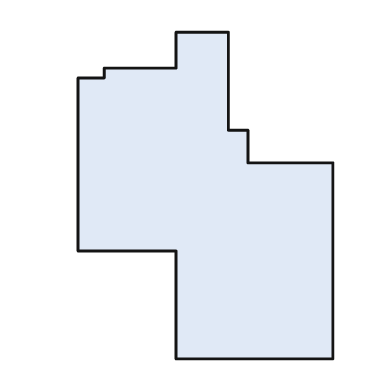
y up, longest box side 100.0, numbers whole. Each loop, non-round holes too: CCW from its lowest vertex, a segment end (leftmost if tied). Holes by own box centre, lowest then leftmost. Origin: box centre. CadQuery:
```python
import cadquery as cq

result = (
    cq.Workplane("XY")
    .moveTo(-9.0, -50.0)
    .lineTo(39.0, -50.0)
    .lineTo(39.0, 10.0)
    .lineTo(13.0, 10.0)
    .lineTo(13.0, 20.0)
    .lineTo(7.0, 20.0)
    .lineTo(7.0, 50.0)
    .lineTo(-9.0, 50.0)
    .lineTo(-9.0, 39.0)
    .lineTo(-31.0, 39.0)
    .lineTo(-31.0, 36.0)
    .lineTo(-39.0, 36.0)
    .lineTo(-39.0, -17.0)
    .lineTo(-9.0, -17.0)
    .close()
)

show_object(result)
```